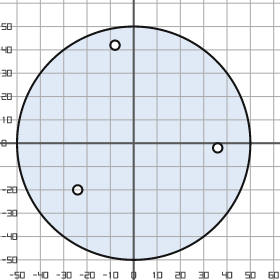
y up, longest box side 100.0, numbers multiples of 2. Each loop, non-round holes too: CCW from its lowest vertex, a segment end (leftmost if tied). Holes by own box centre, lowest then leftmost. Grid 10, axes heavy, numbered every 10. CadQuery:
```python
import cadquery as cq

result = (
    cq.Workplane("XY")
    .moveTo(0.0, 0.0)
    .circle(50.0)
    .moveTo(-24.0, -20.0)
    .circle(2.0)
    .moveTo(36.0, -2.0)
    .circle(2.0)
    .moveTo(-8.0, 42.0)
    .circle(2.0)
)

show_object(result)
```